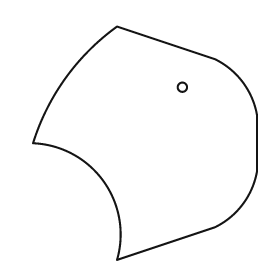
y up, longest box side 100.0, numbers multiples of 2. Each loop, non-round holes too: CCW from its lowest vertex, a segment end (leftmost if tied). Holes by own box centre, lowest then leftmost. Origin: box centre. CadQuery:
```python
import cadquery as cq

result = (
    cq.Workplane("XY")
    .moveTo(-12.0, -50.0)
    .lineTo(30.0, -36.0)
    .threePointArc((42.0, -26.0), (48.0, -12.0))
    .lineTo(48.0, 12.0)
    .threePointArc((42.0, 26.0), (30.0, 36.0))
    .lineTo(-12.0, 50.0)
    .threePointArc((-34.0, 28.0), (-48.0, 0.0))
    .threePointArc((-18.0, -16.0), (-12.0, -50.0))
    .close()
    .moveTo(16.0, 24.0)
    .circle(2.0)
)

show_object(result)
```